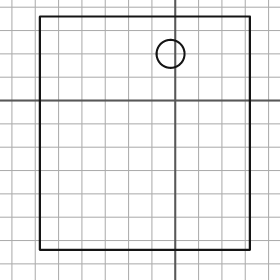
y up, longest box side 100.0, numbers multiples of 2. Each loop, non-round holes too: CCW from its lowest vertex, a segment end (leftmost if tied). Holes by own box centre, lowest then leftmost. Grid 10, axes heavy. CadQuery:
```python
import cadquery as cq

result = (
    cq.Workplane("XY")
    .moveTo(-58.0, -64.0)
    .lineTo(32.0, -64.0)
    .lineTo(32.0, 36.0)
    .lineTo(-58.0, 36.0)
    .close()
    .moveTo(-2.0, 20.0)
    .circle(6.0)
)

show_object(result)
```